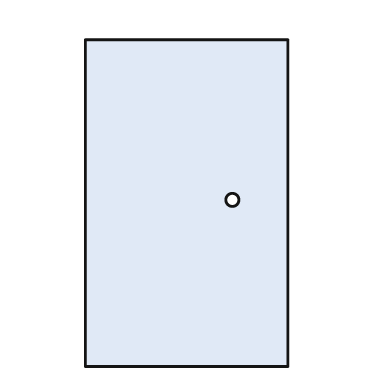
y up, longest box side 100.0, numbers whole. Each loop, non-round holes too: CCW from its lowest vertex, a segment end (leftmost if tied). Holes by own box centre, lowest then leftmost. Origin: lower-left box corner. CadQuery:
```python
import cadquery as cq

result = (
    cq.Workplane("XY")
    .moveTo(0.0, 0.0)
    .lineTo(62.0, 0.0)
    .lineTo(62.0, 100.0)
    .lineTo(0.0, 100.0)
    .close()
    .moveTo(45.0, 51.0)
    .circle(2.0)
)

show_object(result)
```